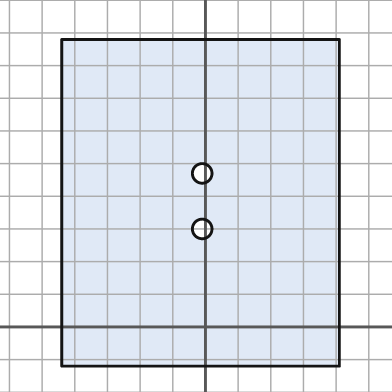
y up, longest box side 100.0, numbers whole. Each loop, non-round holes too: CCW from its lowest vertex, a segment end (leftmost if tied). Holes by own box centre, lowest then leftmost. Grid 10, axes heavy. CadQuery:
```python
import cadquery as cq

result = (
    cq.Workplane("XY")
    .moveTo(-44.0, -12.0)
    .lineTo(41.0, -12.0)
    .lineTo(41.0, 88.0)
    .lineTo(-44.0, 88.0)
    .close()
    .moveTo(-1.0, 30.0)
    .circle(3.0)
    .moveTo(-1.0, 47.0)
    .circle(3.0)
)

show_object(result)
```